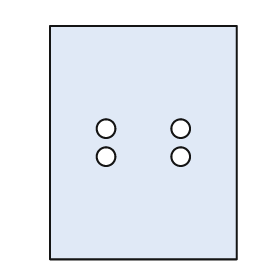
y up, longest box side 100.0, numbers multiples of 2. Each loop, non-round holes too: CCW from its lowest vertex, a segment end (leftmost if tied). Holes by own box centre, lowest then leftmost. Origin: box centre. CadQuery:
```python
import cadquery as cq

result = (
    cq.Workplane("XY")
    .moveTo(-40.0, -50.0)
    .lineTo(40.0, -50.0)
    .lineTo(40.0, 50.0)
    .lineTo(-40.0, 50.0)
    .close()
    .moveTo(-16.0, -6.0)
    .circle(4.0)
    .moveTo(16.0, -6.0)
    .circle(4.0)
    .moveTo(-16.0, 6.0)
    .circle(4.0)
    .moveTo(16.0, 6.0)
    .circle(4.0)
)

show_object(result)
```